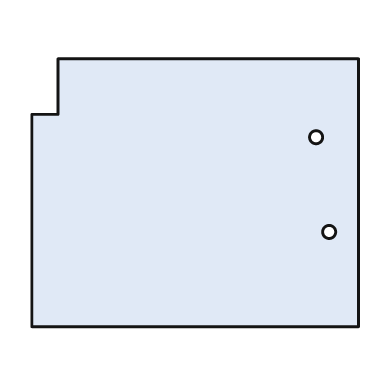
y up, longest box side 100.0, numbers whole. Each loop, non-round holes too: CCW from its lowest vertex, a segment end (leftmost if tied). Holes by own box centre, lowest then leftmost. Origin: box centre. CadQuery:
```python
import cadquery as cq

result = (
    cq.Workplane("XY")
    .moveTo(-50.0, -41.0)
    .lineTo(50.0, -41.0)
    .lineTo(50.0, 41.0)
    .lineTo(-42.0, 41.0)
    .lineTo(-42.0, 24.0)
    .lineTo(-50.0, 24.0)
    .close()
    .moveTo(41.0, -12.0)
    .circle(2.0)
    .moveTo(37.0, 17.0)
    .circle(2.0)
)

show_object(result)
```